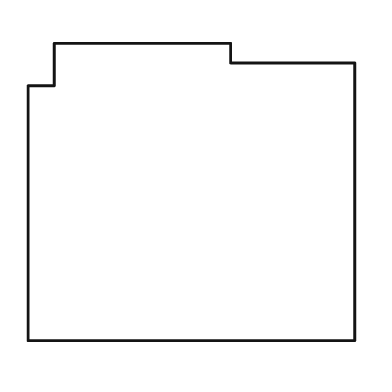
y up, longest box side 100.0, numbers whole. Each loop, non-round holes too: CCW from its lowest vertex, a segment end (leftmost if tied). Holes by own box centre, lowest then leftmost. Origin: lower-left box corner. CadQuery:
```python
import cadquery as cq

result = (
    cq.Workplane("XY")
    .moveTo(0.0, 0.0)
    .lineTo(100.0, 0.0)
    .lineTo(100.0, 85.0)
    .lineTo(62.0, 85.0)
    .lineTo(62.0, 91.0)
    .lineTo(8.0, 91.0)
    .lineTo(8.0, 78.0)
    .lineTo(0.0, 78.0)
    .close()
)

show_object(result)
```